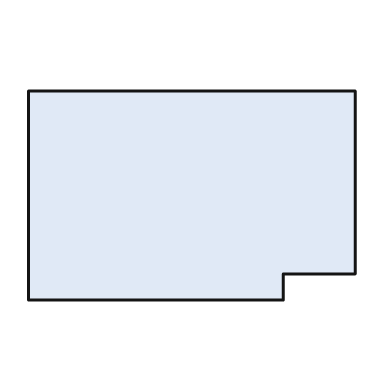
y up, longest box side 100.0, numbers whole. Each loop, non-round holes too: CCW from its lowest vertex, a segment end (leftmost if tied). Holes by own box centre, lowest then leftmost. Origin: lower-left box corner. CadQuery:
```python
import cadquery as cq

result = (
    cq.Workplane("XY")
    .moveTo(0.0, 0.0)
    .lineTo(78.0, 0.0)
    .lineTo(78.0, 8.0)
    .lineTo(100.0, 8.0)
    .lineTo(100.0, 64.0)
    .lineTo(0.0, 64.0)
    .close()
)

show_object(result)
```